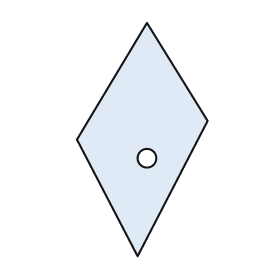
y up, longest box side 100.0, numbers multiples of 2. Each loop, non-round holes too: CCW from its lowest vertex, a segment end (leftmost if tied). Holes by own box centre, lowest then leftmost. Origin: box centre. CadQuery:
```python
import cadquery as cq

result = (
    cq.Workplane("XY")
    .moveTo(-2.0, -50.0)
    .lineTo(28.0, 8.0)
    .lineTo(2.0, 50.0)
    .lineTo(-28.0, 0.0)
    .close()
    .moveTo(2.0, -8.0)
    .circle(4.0)
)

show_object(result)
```